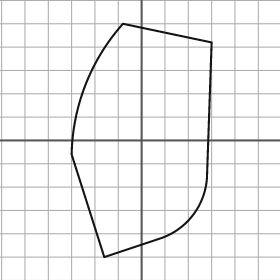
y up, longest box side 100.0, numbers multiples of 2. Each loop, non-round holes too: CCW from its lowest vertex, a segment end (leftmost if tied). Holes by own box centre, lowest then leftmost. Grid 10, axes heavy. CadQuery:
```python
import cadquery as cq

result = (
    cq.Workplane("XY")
    .moveTo(-16.0, -50.0)
    .lineTo(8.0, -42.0)
    .threePointArc((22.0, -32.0), (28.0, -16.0))
    .lineTo(30.0, 42.0)
    .lineTo(-8.0, 50.0)
    .threePointArc((-24.0, 24.0), (-30.0, -6.0))
    .close()
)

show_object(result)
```